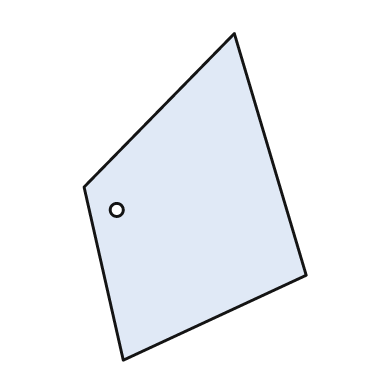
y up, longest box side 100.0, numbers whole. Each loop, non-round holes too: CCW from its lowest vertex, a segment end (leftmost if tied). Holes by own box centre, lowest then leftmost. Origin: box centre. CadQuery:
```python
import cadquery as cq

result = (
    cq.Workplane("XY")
    .moveTo(-22.0, -50.0)
    .lineTo(34.0, -24.0)
    .lineTo(12.0, 50.0)
    .lineTo(-34.0, 3.0)
    .close()
    .moveTo(-24.0, -4.0)
    .circle(2.0)
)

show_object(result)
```